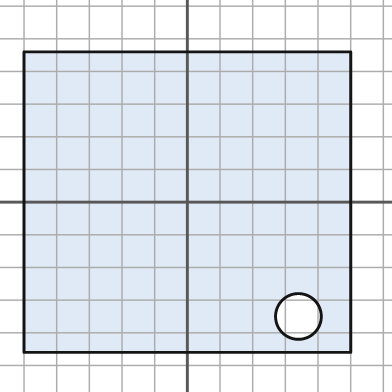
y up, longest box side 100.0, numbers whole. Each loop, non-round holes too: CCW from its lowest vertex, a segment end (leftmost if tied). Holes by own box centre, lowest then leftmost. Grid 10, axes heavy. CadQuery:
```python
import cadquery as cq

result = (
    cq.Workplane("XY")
    .moveTo(-50.0, -46.0)
    .lineTo(50.0, -46.0)
    .lineTo(50.0, 46.0)
    .lineTo(-50.0, 46.0)
    .close()
    .moveTo(34.0, -35.0)
    .circle(7.0)
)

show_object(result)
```